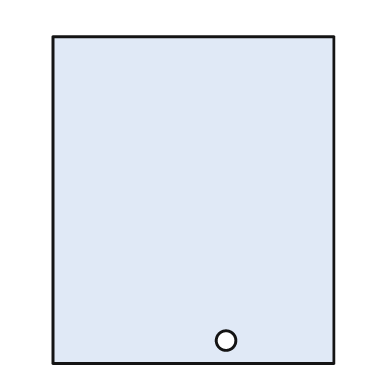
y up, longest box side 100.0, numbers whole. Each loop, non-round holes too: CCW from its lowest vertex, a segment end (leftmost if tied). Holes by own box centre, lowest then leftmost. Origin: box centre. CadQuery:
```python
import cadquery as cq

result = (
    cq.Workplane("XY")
    .moveTo(-43.0, -50.0)
    .lineTo(43.0, -50.0)
    .lineTo(43.0, 50.0)
    .lineTo(-43.0, 50.0)
    .close()
    .moveTo(10.0, -43.0)
    .circle(3.0)
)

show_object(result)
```